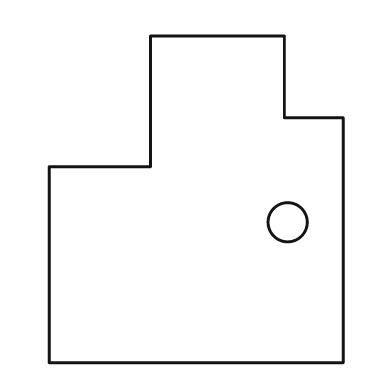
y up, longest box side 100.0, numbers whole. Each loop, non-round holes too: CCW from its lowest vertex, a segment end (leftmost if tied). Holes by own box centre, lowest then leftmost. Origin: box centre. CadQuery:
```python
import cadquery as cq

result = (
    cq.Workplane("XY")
    .moveTo(-45.0, -50.0)
    .lineTo(45.0, -50.0)
    .lineTo(45.0, 25.0)
    .lineTo(27.0, 25.0)
    .lineTo(27.0, 50.0)
    .lineTo(-14.0, 50.0)
    .lineTo(-14.0, 10.0)
    .lineTo(-45.0, 10.0)
    .close()
    .moveTo(28.0, -7.0)
    .circle(6.0)
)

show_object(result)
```